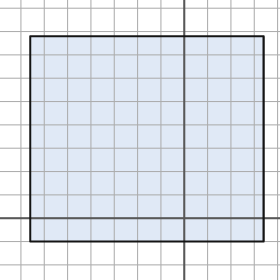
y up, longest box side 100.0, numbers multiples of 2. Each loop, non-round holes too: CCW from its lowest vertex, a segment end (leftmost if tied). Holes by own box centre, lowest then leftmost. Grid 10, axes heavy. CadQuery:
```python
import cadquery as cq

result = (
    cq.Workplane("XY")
    .moveTo(-66.0, -10.0)
    .lineTo(34.0, -10.0)
    .lineTo(34.0, 78.0)
    .lineTo(-66.0, 78.0)
    .close()
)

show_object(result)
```